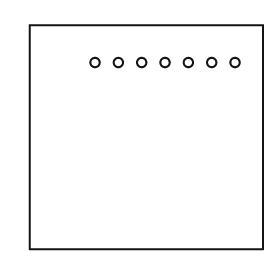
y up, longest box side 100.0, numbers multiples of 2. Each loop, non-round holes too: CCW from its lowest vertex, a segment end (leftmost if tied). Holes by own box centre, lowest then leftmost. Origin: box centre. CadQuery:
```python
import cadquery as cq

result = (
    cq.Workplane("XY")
    .moveTo(-50.0, -48.0)
    .lineTo(50.0, -48.0)
    .lineTo(50.0, 48.0)
    .lineTo(-50.0, 48.0)
    .close()
    .moveTo(-22.0, 32.0)
    .circle(2.0)
    .moveTo(-12.0, 32.0)
    .circle(2.0)
    .moveTo(-2.0, 32.0)
    .circle(2.0)
    .moveTo(8.0, 32.0)
    .circle(2.0)
    .moveTo(18.0, 32.0)
    .circle(2.0)
    .moveTo(28.0, 32.0)
    .circle(2.0)
    .moveTo(38.0, 32.0)
    .circle(2.0)
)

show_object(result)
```